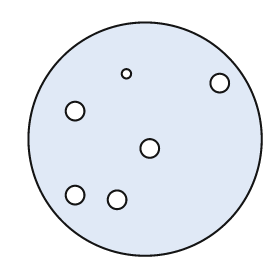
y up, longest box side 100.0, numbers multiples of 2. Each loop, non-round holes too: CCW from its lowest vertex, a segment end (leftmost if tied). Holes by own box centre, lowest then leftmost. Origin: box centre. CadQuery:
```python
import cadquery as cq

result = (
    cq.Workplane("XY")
    .moveTo(0.0, 0.0)
    .circle(50.0)
    .moveTo(-12.0, -26.0)
    .circle(4.0)
    .moveTo(-30.0, -24.0)
    .circle(4.0)
    .moveTo(2.0, -4.0)
    .circle(4.0)
    .moveTo(-30.0, 12.0)
    .circle(4.0)
    .moveTo(32.0, 24.0)
    .circle(4.0)
    .moveTo(-8.0, 28.0)
    .circle(2.0)
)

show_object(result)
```